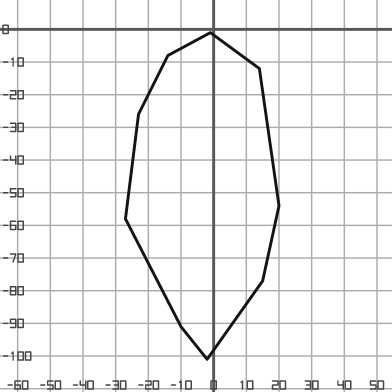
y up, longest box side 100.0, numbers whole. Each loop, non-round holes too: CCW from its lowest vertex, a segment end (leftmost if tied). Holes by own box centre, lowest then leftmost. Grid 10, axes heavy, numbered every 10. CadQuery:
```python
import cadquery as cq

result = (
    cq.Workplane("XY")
    .moveTo(-2.0, -101.0)
    .lineTo(15.0, -77.0)
    .lineTo(20.0, -54.0)
    .lineTo(14.0, -12.0)
    .lineTo(-1.0, -1.0)
    .lineTo(-14.0, -8.0)
    .lineTo(-23.0, -26.0)
    .lineTo(-27.0, -58.0)
    .lineTo(-10.0, -91.0)
    .close()
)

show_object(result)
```